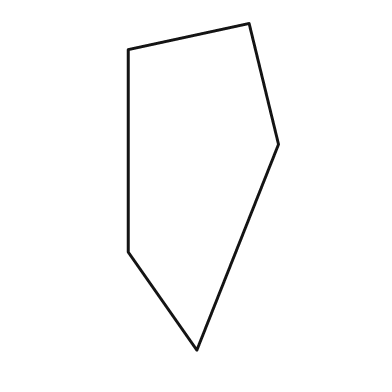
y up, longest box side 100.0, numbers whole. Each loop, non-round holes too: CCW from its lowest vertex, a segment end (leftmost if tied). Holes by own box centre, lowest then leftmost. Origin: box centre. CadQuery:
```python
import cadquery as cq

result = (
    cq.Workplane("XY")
    .moveTo(-2.0, -50.0)
    .lineTo(23.0, 13.0)
    .lineTo(14.0, 50.0)
    .lineTo(-23.0, 42.0)
    .lineTo(-23.0, -20.0)
    .close()
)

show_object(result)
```